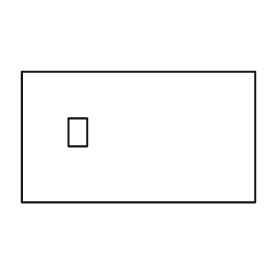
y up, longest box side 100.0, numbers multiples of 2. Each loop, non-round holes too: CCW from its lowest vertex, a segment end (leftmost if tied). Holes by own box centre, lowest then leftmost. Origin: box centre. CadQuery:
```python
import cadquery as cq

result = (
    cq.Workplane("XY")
    .moveTo(-50.0, -28.0)
    .lineTo(50.0, -28.0)
    .lineTo(50.0, 28.0)
    .lineTo(-50.0, 28.0)
    .close()
    .moveTo(-30.0, -4.0)
    .lineTo(-22.0, -4.0)
    .lineTo(-22.0, 8.0)
    .lineTo(-30.0, 8.0)
    .close()
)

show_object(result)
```